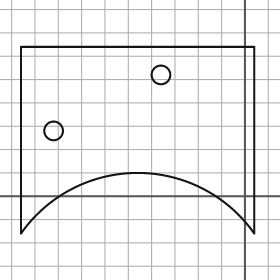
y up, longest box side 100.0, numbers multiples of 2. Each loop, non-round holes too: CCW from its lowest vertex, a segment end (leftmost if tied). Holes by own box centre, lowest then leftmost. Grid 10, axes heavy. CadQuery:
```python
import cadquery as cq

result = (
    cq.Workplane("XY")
    .moveTo(-96.0, -16.0)
    .threePointArc((-46.0, 10.0), (4.0, -16.0))
    .lineTo(4.0, 64.0)
    .lineTo(-96.0, 64.0)
    .close()
    .moveTo(-82.0, 28.0)
    .circle(4.0)
    .moveTo(-36.0, 52.0)
    .circle(4.0)
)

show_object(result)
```